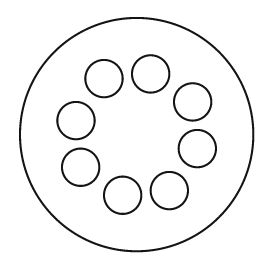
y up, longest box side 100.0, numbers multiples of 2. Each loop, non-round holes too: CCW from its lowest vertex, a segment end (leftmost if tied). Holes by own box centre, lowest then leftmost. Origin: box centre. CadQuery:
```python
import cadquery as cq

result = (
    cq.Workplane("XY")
    .moveTo(0.0, 0.0)
    .circle(50.0)
    .moveTo(-6.0, -26.0)
    .circle(8.0)
    .moveTo(14.0, -24.0)
    .circle(8.0)
    .moveTo(-24.0, -14.0)
    .circle(8.0)
    .moveTo(26.0, -6.0)
    .circle(8.0)
    .moveTo(-26.0, 6.0)
    .circle(8.0)
    .moveTo(24.0, 14.0)
    .circle(8.0)
    .moveTo(-14.0, 24.0)
    .circle(8.0)
    .moveTo(6.0, 26.0)
    .circle(8.0)
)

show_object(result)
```